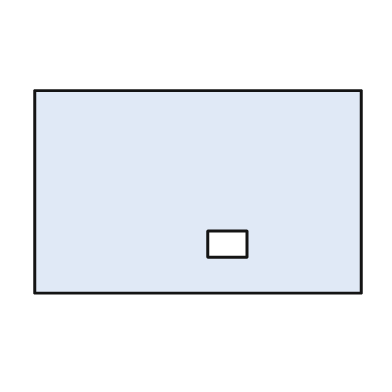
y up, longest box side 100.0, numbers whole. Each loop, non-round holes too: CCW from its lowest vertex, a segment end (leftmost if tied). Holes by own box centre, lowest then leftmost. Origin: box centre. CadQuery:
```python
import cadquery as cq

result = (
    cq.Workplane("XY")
    .moveTo(-50.0, -31.0)
    .lineTo(50.0, -31.0)
    .lineTo(50.0, 31.0)
    .lineTo(-50.0, 31.0)
    .close()
    .moveTo(3.0, -20.0)
    .lineTo(15.0, -20.0)
    .lineTo(15.0, -12.0)
    .lineTo(3.0, -12.0)
    .close()
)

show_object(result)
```